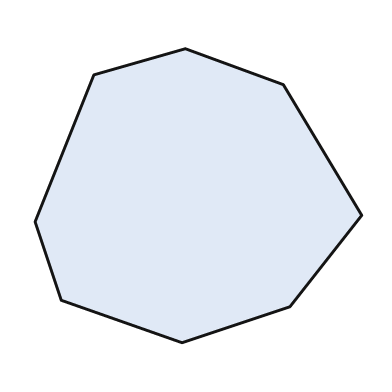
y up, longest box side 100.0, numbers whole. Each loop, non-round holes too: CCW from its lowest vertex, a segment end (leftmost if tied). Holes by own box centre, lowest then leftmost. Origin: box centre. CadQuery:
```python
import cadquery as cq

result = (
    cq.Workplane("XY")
    .moveTo(-5.0, -45.0)
    .lineTo(28.0, -34.0)
    .lineTo(50.0, -6.0)
    .lineTo(26.0, 34.0)
    .lineTo(-4.0, 45.0)
    .lineTo(-32.0, 37.0)
    .lineTo(-50.0, -8.0)
    .lineTo(-42.0, -32.0)
    .close()
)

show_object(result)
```